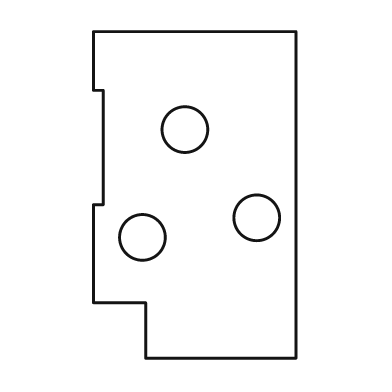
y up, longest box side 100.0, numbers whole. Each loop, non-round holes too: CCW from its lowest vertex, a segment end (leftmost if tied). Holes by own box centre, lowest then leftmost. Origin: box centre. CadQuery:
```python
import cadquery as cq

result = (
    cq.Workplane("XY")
    .moveTo(-15.0, -50.0)
    .lineTo(31.0, -50.0)
    .lineTo(31.0, 50.0)
    .lineTo(-31.0, 50.0)
    .lineTo(-31.0, 32.0)
    .lineTo(-28.0, 32.0)
    .lineTo(-28.0, -3.0)
    .lineTo(-31.0, -3.0)
    .lineTo(-31.0, -33.0)
    .lineTo(-15.0, -33.0)
    .close()
    .moveTo(-16.0, -13.0)
    .circle(7.0)
    .moveTo(19.0, -7.0)
    .circle(7.0)
    .moveTo(-3.0, 20.0)
    .circle(7.0)
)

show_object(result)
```